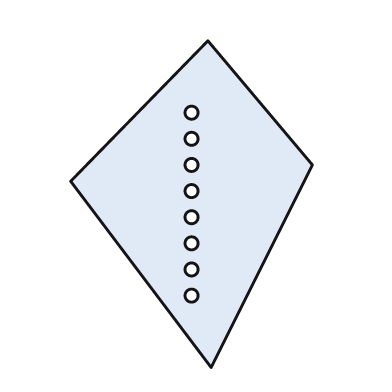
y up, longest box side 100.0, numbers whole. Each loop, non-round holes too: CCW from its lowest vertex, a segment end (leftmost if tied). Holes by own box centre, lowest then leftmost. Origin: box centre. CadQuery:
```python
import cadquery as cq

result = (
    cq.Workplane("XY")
    .moveTo(6.0, -50.0)
    .lineTo(37.0, 12.0)
    .lineTo(5.0, 50.0)
    .lineTo(-37.0, 7.0)
    .close()
    .moveTo(0.0, -28.0)
    .circle(2.0)
    .moveTo(0.0, -20.0)
    .circle(2.0)
    .moveTo(0.0, -12.0)
    .circle(2.0)
    .moveTo(0.0, -4.0)
    .circle(2.0)
    .moveTo(0.0, 4.0)
    .circle(2.0)
    .moveTo(0.0, 12.0)
    .circle(2.0)
    .moveTo(0.0, 20.0)
    .circle(2.0)
    .moveTo(0.0, 28.0)
    .circle(2.0)
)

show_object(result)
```